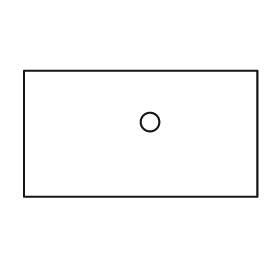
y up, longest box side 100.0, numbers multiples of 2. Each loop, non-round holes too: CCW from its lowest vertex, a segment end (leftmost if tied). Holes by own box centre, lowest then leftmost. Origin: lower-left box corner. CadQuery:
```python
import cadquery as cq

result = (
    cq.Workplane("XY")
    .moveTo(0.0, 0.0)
    .lineTo(100.0, 0.0)
    .lineTo(100.0, 54.0)
    .lineTo(0.0, 54.0)
    .close()
    .moveTo(54.0, 32.0)
    .circle(4.0)
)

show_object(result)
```